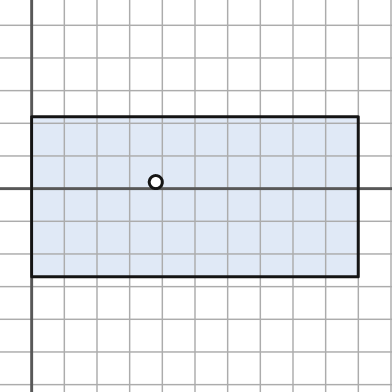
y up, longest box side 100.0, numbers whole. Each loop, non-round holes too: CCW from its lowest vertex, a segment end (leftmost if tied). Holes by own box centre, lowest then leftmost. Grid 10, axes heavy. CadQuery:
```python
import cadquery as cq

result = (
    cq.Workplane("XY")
    .moveTo(0.0, -27.0)
    .lineTo(100.0, -27.0)
    .lineTo(100.0, 22.0)
    .lineTo(0.0, 22.0)
    .close()
    .moveTo(38.0, 2.0)
    .circle(2.0)
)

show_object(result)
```